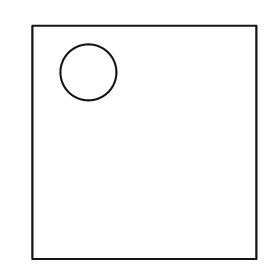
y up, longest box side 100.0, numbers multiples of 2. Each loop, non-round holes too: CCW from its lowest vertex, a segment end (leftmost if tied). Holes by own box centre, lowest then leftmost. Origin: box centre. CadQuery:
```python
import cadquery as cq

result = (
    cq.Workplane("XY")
    .moveTo(-48.0, -50.0)
    .lineTo(48.0, -50.0)
    .lineTo(48.0, 50.0)
    .lineTo(-48.0, 50.0)
    .close()
    .moveTo(-24.0, 30.0)
    .circle(12.0)
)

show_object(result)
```